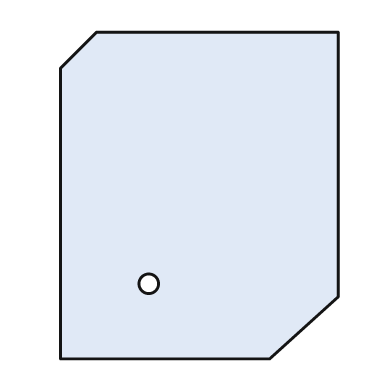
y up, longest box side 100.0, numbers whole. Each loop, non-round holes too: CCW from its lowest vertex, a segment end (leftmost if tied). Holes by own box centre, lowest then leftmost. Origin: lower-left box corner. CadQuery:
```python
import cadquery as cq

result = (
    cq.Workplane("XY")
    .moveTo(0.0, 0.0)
    .lineTo(64.0, 0.0)
    .lineTo(85.0, 19.0)
    .lineTo(85.0, 100.0)
    .lineTo(11.0, 100.0)
    .lineTo(0.0, 89.0)
    .close()
    .moveTo(27.0, 23.0)
    .circle(3.0)
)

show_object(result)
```